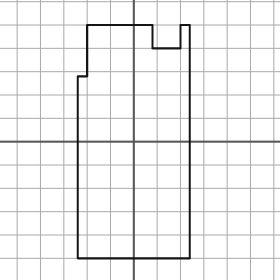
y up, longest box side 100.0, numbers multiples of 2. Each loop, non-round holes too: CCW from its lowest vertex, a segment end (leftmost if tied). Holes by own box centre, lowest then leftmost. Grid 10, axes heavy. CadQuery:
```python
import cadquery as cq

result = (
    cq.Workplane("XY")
    .moveTo(-24.0, -50.0)
    .lineTo(24.0, -50.0)
    .lineTo(24.0, 50.0)
    .lineTo(20.0, 50.0)
    .lineTo(20.0, 40.0)
    .lineTo(8.0, 40.0)
    .lineTo(8.0, 50.0)
    .lineTo(-20.0, 50.0)
    .lineTo(-20.0, 28.0)
    .lineTo(-24.0, 28.0)
    .close()
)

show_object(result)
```